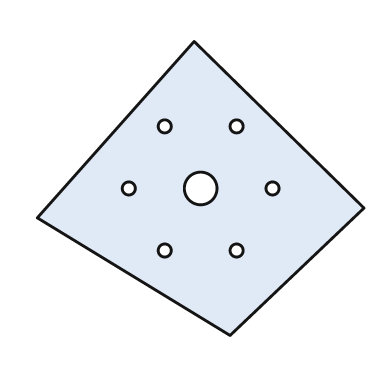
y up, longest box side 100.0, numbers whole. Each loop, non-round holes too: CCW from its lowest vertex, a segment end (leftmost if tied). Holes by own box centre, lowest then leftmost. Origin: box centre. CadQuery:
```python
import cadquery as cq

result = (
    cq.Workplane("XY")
    .moveTo(9.0, -45.0)
    .lineTo(50.0, -6.0)
    .lineTo(-2.0, 45.0)
    .lineTo(-50.0, -9.0)
    .close()
    .moveTo(-11.0, -19.0)
    .circle(2.0)
    .moveTo(11.0, -19.0)
    .circle(2.0)
    .moveTo(-22.0, 0.0)
    .circle(2.0)
    .moveTo(0.0, 0.0)
    .circle(5.0)
    .moveTo(22.0, 0.0)
    .circle(2.0)
    .moveTo(-11.0, 19.0)
    .circle(2.0)
    .moveTo(11.0, 19.0)
    .circle(2.0)
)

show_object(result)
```